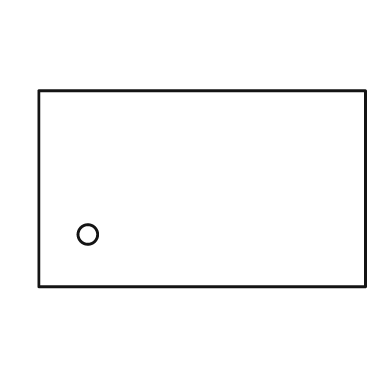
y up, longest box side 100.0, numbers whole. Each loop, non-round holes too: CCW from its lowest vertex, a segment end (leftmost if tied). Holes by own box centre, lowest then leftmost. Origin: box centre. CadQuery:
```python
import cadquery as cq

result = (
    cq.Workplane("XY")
    .moveTo(-50.0, -30.0)
    .lineTo(50.0, -30.0)
    .lineTo(50.0, 30.0)
    .lineTo(-50.0, 30.0)
    .close()
    .moveTo(-35.0, -14.0)
    .circle(3.0)
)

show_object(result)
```